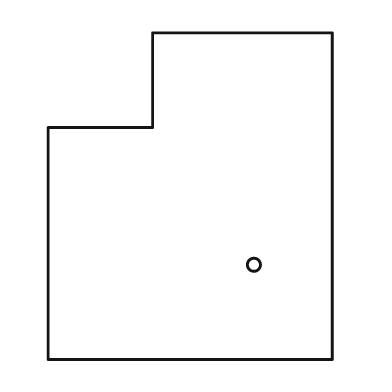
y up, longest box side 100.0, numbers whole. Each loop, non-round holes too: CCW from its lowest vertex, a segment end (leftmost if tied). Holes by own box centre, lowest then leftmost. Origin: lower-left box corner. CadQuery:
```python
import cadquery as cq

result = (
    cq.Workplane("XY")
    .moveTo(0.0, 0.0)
    .lineTo(87.0, 0.0)
    .lineTo(87.0, 100.0)
    .lineTo(32.0, 100.0)
    .lineTo(32.0, 71.0)
    .lineTo(0.0, 71.0)
    .close()
    .moveTo(63.0, 29.0)
    .circle(2.0)
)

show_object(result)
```